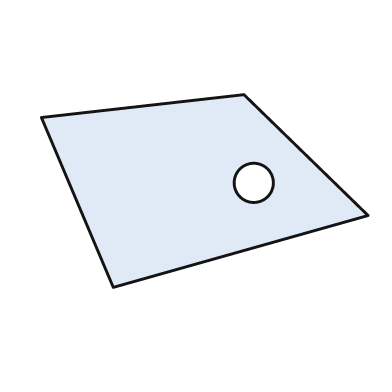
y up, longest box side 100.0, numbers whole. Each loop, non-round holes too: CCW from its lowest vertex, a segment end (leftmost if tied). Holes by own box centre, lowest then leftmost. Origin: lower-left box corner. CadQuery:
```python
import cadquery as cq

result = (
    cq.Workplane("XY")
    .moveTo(22.0, 0.0)
    .lineTo(100.0, 22.0)
    .lineTo(62.0, 59.0)
    .lineTo(0.0, 52.0)
    .close()
    .moveTo(65.0, 32.0)
    .circle(6.0)
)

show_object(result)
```